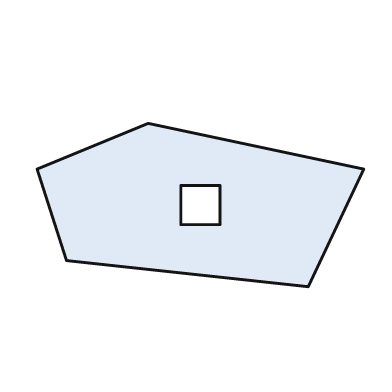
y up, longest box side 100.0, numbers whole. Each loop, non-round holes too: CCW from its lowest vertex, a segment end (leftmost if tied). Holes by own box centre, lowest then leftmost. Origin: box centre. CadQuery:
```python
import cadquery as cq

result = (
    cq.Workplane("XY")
    .moveTo(33.0, -25.0)
    .lineTo(50.0, 11.0)
    .lineTo(-16.0, 25.0)
    .lineTo(-50.0, 11.0)
    .lineTo(-41.0, -17.0)
    .close()
    .moveTo(-6.0, -6.0)
    .lineTo(6.0, -6.0)
    .lineTo(6.0, 6.0)
    .lineTo(-6.0, 6.0)
    .close()
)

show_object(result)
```